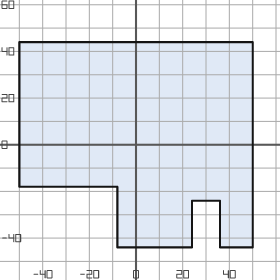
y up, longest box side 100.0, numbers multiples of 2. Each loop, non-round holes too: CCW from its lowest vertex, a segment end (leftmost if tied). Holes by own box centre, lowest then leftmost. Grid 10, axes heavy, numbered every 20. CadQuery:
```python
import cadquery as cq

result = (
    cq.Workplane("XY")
    .moveTo(-8.0, -44.0)
    .lineTo(24.0, -44.0)
    .lineTo(24.0, -24.0)
    .lineTo(36.0, -24.0)
    .lineTo(36.0, -44.0)
    .lineTo(50.0, -44.0)
    .lineTo(50.0, 44.0)
    .lineTo(-50.0, 44.0)
    .lineTo(-50.0, -18.0)
    .lineTo(-8.0, -18.0)
    .close()
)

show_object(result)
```